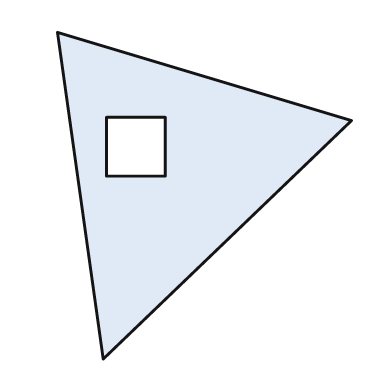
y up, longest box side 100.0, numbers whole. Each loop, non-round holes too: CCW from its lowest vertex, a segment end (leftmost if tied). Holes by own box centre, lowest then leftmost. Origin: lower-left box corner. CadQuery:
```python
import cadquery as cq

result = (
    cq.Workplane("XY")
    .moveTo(14.0, 0.0)
    .lineTo(90.0, 73.0)
    .lineTo(0.0, 100.0)
    .close()
    .moveTo(15.0, 56.0)
    .lineTo(33.0, 56.0)
    .lineTo(33.0, 74.0)
    .lineTo(15.0, 74.0)
    .close()
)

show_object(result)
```